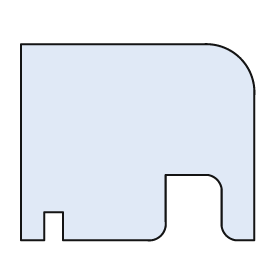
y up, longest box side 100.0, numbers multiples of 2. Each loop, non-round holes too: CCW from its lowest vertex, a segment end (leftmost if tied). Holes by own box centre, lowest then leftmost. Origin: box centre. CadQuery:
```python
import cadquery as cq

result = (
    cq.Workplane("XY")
    .moveTo(-50.0, -42.0)
    .lineTo(-40.0, -42.0)
    .lineTo(-40.0, -30.0)
    .lineTo(-32.0, -30.0)
    .lineTo(-32.0, -42.0)
    .lineTo(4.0, -42.0)
    .threePointArc((10.0, -40.0), (12.0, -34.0))
    .lineTo(12.0, -14.0)
    .lineTo(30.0, -14.0)
    .threePointArc((34.0, -16.0), (36.0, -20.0))
    .lineTo(36.0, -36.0)
    .threePointArc((38.0, -40.0), (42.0, -42.0))
    .lineTo(50.0, -42.0)
    .lineTo(50.0, 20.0)
    .threePointArc((44.0, 36.0), (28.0, 42.0))
    .lineTo(-50.0, 42.0)
    .close()
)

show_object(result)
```